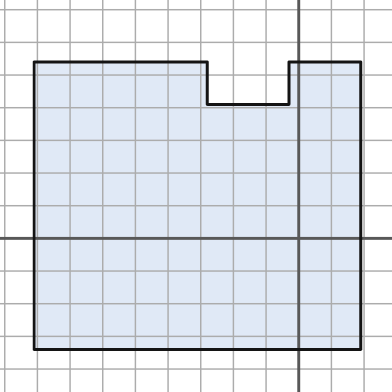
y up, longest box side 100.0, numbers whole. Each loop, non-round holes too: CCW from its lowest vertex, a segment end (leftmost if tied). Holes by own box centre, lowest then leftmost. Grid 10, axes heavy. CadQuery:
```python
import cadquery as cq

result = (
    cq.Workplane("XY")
    .moveTo(-81.0, -34.0)
    .lineTo(19.0, -34.0)
    .lineTo(19.0, 54.0)
    .lineTo(-3.0, 54.0)
    .lineTo(-3.0, 41.0)
    .lineTo(-28.0, 41.0)
    .lineTo(-28.0, 54.0)
    .lineTo(-81.0, 54.0)
    .close()
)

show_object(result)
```